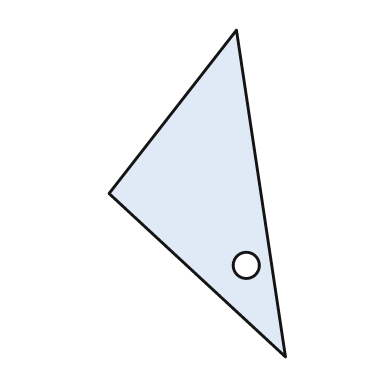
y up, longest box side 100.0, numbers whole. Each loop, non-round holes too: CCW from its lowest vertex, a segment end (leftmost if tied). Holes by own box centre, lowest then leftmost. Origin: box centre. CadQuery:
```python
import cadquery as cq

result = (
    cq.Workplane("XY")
    .moveTo(27.0, -50.0)
    .lineTo(12.0, 50.0)
    .lineTo(-27.0, 0.0)
    .close()
    .moveTo(15.0, -22.0)
    .circle(4.0)
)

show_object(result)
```